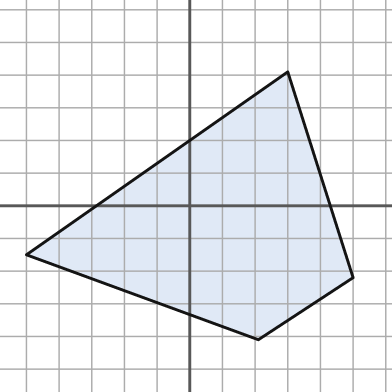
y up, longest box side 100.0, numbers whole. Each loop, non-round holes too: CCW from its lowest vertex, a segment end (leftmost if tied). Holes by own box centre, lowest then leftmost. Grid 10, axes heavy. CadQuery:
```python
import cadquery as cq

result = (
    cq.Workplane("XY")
    .moveTo(21.0, -41.0)
    .lineTo(50.0, -22.0)
    .lineTo(30.0, 41.0)
    .lineTo(-50.0, -15.0)
    .close()
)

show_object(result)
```